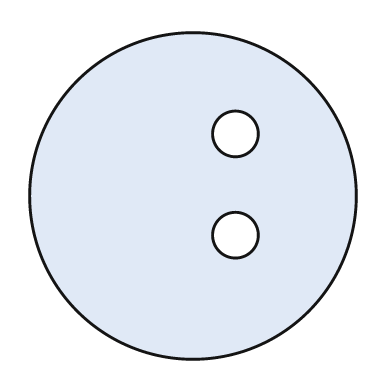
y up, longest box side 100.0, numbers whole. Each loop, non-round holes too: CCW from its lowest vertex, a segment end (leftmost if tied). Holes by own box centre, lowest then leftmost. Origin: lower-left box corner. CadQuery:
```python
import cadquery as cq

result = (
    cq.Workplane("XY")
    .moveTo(50.0, 50.0)
    .circle(50.0)
    .moveTo(63.0, 38.0)
    .circle(7.0)
    .moveTo(63.0, 69.0)
    .circle(7.0)
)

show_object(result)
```